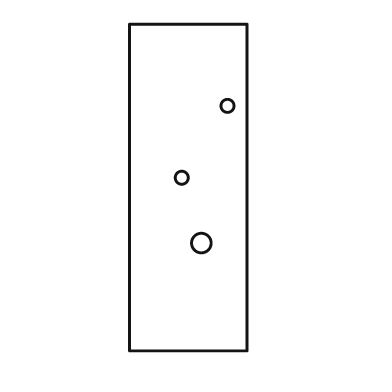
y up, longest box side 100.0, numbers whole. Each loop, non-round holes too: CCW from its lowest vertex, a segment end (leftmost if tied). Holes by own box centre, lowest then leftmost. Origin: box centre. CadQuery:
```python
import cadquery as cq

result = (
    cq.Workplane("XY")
    .moveTo(-18.0, -50.0)
    .lineTo(18.0, -50.0)
    .lineTo(18.0, 50.0)
    .lineTo(-18.0, 50.0)
    .close()
    .moveTo(4.0, -17.0)
    .circle(3.0)
    .moveTo(-2.0, 3.0)
    .circle(2.0)
    .moveTo(12.0, 25.0)
    .circle(2.0)
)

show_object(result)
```